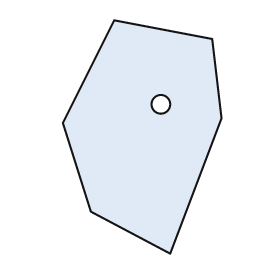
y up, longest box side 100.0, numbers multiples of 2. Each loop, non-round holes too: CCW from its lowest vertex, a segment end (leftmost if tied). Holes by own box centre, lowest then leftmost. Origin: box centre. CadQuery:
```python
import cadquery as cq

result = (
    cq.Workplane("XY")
    .moveTo(12.0, -50.0)
    .lineTo(34.0, 8.0)
    .lineTo(30.0, 42.0)
    .lineTo(-12.0, 50.0)
    .lineTo(-34.0, 6.0)
    .lineTo(-22.0, -32.0)
    .close()
    .moveTo(8.0, 14.0)
    .circle(4.0)
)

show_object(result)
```